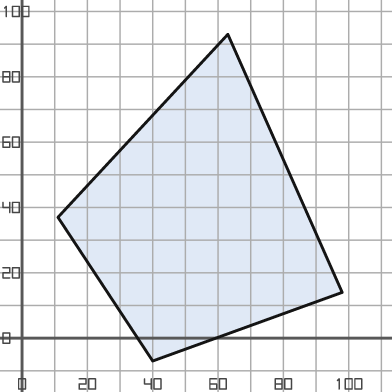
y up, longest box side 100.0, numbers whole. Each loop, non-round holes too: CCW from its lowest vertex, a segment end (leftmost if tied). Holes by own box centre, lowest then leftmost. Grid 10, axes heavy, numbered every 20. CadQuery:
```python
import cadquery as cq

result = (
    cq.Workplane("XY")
    .moveTo(40.0, -7.0)
    .lineTo(98.0, 14.0)
    .lineTo(63.0, 93.0)
    .lineTo(11.0, 37.0)
    .close()
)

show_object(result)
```